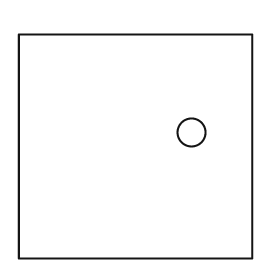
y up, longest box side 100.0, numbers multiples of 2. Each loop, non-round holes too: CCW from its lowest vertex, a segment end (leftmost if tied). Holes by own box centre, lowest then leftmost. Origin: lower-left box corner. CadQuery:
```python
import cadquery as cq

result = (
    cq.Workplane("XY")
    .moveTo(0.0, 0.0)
    .lineTo(100.0, 0.0)
    .lineTo(100.0, 96.0)
    .lineTo(0.0, 96.0)
    .close()
    .moveTo(74.0, 54.0)
    .circle(6.0)
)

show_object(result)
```